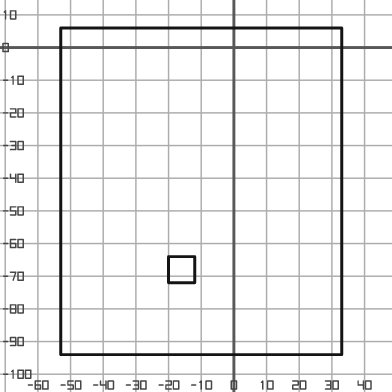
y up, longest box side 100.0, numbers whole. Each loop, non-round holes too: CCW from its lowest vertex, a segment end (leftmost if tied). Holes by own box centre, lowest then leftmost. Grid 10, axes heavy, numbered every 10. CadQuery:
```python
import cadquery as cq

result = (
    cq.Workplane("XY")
    .moveTo(-53.0, -94.0)
    .lineTo(33.0, -94.0)
    .lineTo(33.0, 6.0)
    .lineTo(-53.0, 6.0)
    .close()
    .moveTo(-20.0, -72.0)
    .lineTo(-12.0, -72.0)
    .lineTo(-12.0, -64.0)
    .lineTo(-20.0, -64.0)
    .close()
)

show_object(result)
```